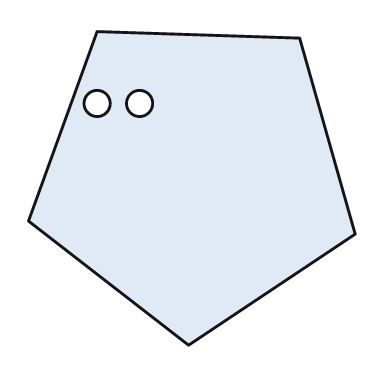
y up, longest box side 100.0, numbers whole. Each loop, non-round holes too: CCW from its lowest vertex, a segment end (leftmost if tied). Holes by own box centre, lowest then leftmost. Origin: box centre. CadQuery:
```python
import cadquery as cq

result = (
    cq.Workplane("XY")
    .moveTo(-1.0, -48.0)
    .lineTo(50.0, -14.0)
    .lineTo(33.0, 46.0)
    .lineTo(-29.0, 48.0)
    .lineTo(-50.0, -10.0)
    .close()
    .moveTo(-29.0, 26.0)
    .circle(4.0)
    .moveTo(-16.0, 26.0)
    .circle(4.0)
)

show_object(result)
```